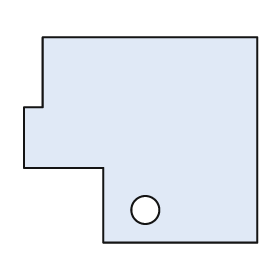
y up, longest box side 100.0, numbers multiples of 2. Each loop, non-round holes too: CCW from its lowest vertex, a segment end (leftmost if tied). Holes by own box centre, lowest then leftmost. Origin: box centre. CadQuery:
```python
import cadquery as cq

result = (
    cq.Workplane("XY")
    .moveTo(-16.0, -44.0)
    .lineTo(50.0, -44.0)
    .lineTo(50.0, 44.0)
    .lineTo(-42.0, 44.0)
    .lineTo(-42.0, 14.0)
    .lineTo(-50.0, 14.0)
    .lineTo(-50.0, -12.0)
    .lineTo(-16.0, -12.0)
    .close()
    .moveTo(2.0, -30.0)
    .circle(6.0)
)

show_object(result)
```